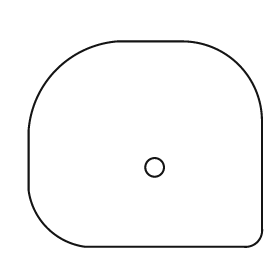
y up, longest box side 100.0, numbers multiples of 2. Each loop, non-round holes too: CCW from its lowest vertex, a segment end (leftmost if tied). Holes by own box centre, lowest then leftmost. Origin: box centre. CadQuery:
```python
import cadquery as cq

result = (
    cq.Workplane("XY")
    .moveTo(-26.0, -44.0)
    .lineTo(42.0, -44.0)
    .threePointArc((48.0, -42.0), (50.0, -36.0))
    .lineTo(50.0, 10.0)
    .threePointArc((40.0, 34.0), (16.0, 44.0))
    .lineTo(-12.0, 44.0)
    .threePointArc((-38.0, 32.0), (-50.0, 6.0))
    .lineTo(-50.0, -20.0)
    .threePointArc((-42.0, -36.0), (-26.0, -44.0))
    .close()
    .moveTo(4.0, -10.0)
    .circle(4.0)
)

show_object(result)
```